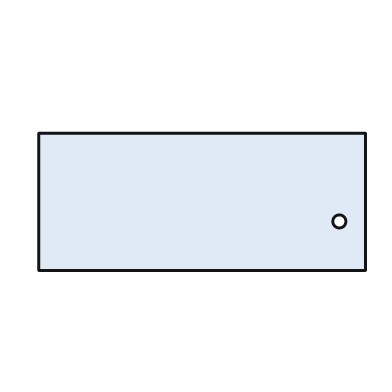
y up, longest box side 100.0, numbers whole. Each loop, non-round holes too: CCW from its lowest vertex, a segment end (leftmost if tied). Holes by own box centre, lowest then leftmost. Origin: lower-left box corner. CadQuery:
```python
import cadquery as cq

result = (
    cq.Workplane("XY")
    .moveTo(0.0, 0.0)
    .lineTo(100.0, 0.0)
    .lineTo(100.0, 42.0)
    .lineTo(0.0, 42.0)
    .close()
    .moveTo(92.0, 15.0)
    .circle(2.0)
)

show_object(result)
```